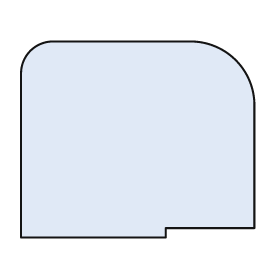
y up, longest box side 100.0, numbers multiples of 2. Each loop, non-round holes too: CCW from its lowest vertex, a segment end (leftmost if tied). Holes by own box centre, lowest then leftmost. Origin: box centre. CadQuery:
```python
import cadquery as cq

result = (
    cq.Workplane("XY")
    .moveTo(-50.0, -42.0)
    .lineTo(12.0, -42.0)
    .lineTo(12.0, -38.0)
    .lineTo(50.0, -38.0)
    .lineTo(50.0, 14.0)
    .threePointArc((42.0, 34.0), (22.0, 42.0))
    .lineTo(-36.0, 42.0)
    .threePointArc((-46.0, 38.0), (-50.0, 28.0))
    .close()
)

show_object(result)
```